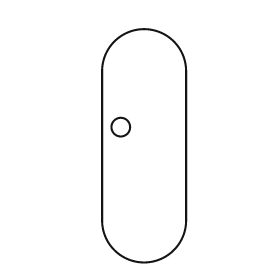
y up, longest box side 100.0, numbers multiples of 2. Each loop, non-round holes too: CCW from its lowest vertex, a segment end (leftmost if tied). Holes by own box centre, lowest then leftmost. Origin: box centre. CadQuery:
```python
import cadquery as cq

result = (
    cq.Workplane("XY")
    .moveTo(-18.0, -32.0)
    .threePointArc((0.0, -50.0), (18.0, -32.0))
    .lineTo(18.0, 32.0)
    .threePointArc((0.0, 50.0), (-18.0, 32.0))
    .close()
    .moveTo(-10.0, 8.0)
    .circle(4.0)
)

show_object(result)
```